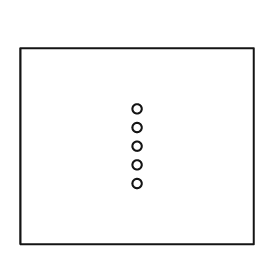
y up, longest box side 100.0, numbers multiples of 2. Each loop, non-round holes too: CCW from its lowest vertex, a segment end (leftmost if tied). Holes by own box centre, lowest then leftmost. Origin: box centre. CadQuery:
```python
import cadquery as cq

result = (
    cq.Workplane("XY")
    .moveTo(-50.0, -42.0)
    .lineTo(50.0, -42.0)
    .lineTo(50.0, 42.0)
    .lineTo(-50.0, 42.0)
    .close()
    .moveTo(0.0, -16.0)
    .circle(2.0)
    .moveTo(0.0, -8.0)
    .circle(2.0)
    .moveTo(0.0, 0.0)
    .circle(2.0)
    .moveTo(0.0, 8.0)
    .circle(2.0)
    .moveTo(0.0, 16.0)
    .circle(2.0)
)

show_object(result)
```